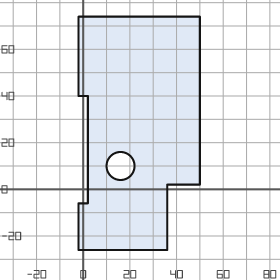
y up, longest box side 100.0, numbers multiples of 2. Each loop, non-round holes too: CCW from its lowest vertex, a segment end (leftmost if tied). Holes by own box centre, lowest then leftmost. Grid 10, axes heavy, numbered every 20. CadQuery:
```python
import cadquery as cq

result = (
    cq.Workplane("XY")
    .moveTo(-2.0, -26.0)
    .lineTo(36.0, -26.0)
    .lineTo(36.0, 2.0)
    .lineTo(50.0, 2.0)
    .lineTo(50.0, 74.0)
    .lineTo(-2.0, 74.0)
    .lineTo(-2.0, 40.0)
    .lineTo(2.0, 40.0)
    .lineTo(2.0, -6.0)
    .lineTo(-2.0, -6.0)
    .close()
    .moveTo(16.0, 10.0)
    .circle(6.0)
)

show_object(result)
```